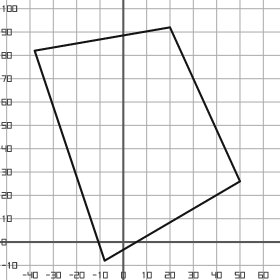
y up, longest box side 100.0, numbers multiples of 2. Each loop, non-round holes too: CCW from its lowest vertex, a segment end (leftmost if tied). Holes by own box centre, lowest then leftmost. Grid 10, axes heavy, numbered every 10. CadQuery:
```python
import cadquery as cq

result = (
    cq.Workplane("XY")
    .moveTo(-8.0, -8.0)
    .lineTo(50.0, 26.0)
    .lineTo(20.0, 92.0)
    .lineTo(-38.0, 82.0)
    .close()
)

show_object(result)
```